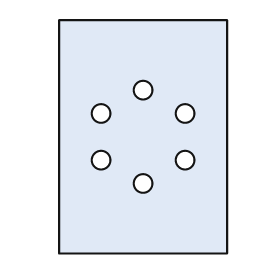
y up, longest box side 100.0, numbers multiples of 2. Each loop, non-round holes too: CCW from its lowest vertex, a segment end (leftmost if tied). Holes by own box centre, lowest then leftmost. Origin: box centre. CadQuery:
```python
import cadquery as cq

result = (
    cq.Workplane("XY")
    .moveTo(-36.0, -50.0)
    .lineTo(36.0, -50.0)
    .lineTo(36.0, 50.0)
    .lineTo(-36.0, 50.0)
    .close()
    .moveTo(0.0, -20.0)
    .circle(4.0)
    .moveTo(-18.0, -10.0)
    .circle(4.0)
    .moveTo(18.0, -10.0)
    .circle(4.0)
    .moveTo(-18.0, 10.0)
    .circle(4.0)
    .moveTo(18.0, 10.0)
    .circle(4.0)
    .moveTo(0.0, 20.0)
    .circle(4.0)
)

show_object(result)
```